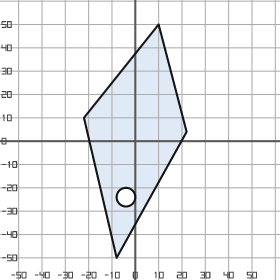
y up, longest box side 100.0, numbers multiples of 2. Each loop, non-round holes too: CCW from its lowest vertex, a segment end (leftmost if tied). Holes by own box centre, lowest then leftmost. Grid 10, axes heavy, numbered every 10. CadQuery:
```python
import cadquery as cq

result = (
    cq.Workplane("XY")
    .moveTo(-8.0, -50.0)
    .lineTo(22.0, 4.0)
    .lineTo(10.0, 50.0)
    .lineTo(-22.0, 10.0)
    .close()
    .moveTo(-4.0, -24.0)
    .circle(4.0)
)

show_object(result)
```